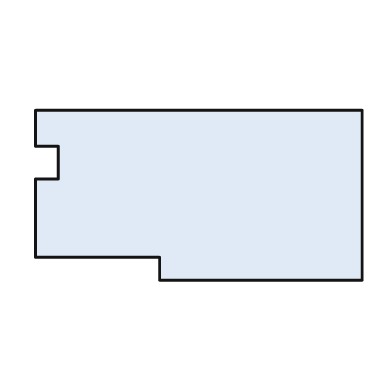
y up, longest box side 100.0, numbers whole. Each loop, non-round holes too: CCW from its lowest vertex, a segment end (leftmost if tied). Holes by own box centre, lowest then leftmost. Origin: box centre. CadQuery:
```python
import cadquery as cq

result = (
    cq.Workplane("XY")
    .moveTo(-12.0, -26.0)
    .lineTo(50.0, -26.0)
    .lineTo(50.0, 26.0)
    .lineTo(-50.0, 26.0)
    .lineTo(-50.0, 15.0)
    .lineTo(-43.0, 15.0)
    .lineTo(-43.0, 5.0)
    .lineTo(-50.0, 5.0)
    .lineTo(-50.0, -19.0)
    .lineTo(-12.0, -19.0)
    .close()
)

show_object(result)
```